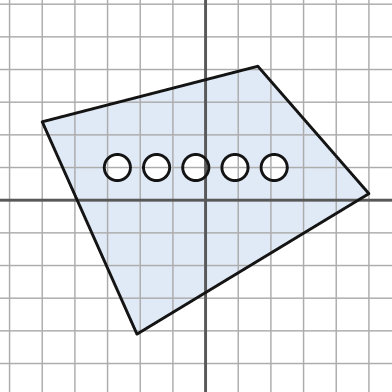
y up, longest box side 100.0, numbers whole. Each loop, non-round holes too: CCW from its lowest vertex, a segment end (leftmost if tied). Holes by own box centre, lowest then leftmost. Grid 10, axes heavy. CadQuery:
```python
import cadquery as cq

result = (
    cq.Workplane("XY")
    .moveTo(-21.0, -41.0)
    .lineTo(50.0, 2.0)
    .lineTo(16.0, 41.0)
    .lineTo(-50.0, 24.0)
    .close()
    .moveTo(-27.0, 10.0)
    .circle(4.0)
    .moveTo(-15.0, 10.0)
    .circle(4.0)
    .moveTo(-3.0, 10.0)
    .circle(4.0)
    .moveTo(9.0, 10.0)
    .circle(4.0)
    .moveTo(21.0, 10.0)
    .circle(4.0)
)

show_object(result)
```